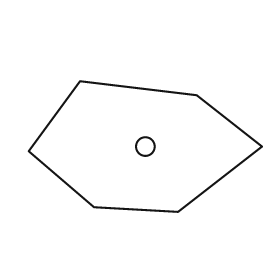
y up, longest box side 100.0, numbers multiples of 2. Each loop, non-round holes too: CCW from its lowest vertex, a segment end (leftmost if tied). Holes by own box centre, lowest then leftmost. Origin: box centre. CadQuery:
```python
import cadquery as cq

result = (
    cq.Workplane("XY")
    .moveTo(14.0, -28.0)
    .lineTo(50.0, 0.0)
    .lineTo(22.0, 22.0)
    .lineTo(-28.0, 28.0)
    .lineTo(-50.0, -2.0)
    .lineTo(-22.0, -26.0)
    .close()
    .moveTo(0.0, 0.0)
    .circle(4.0)
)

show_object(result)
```